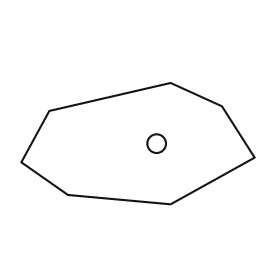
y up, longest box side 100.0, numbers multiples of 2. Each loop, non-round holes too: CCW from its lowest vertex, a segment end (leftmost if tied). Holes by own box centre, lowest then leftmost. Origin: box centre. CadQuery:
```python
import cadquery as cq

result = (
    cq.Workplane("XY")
    .moveTo(14.0, -26.0)
    .lineTo(50.0, -6.0)
    .lineTo(36.0, 16.0)
    .lineTo(14.0, 26.0)
    .lineTo(-38.0, 14.0)
    .lineTo(-50.0, -8.0)
    .lineTo(-30.0, -22.0)
    .close()
    .moveTo(8.0, 0.0)
    .circle(4.0)
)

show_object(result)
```